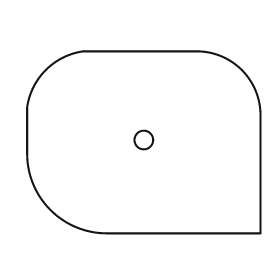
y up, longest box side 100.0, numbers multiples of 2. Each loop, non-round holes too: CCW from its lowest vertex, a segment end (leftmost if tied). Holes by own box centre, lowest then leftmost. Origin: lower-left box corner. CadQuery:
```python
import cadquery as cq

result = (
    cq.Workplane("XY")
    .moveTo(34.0, 0.0)
    .lineTo(100.0, 0.0)
    .lineTo(100.0, 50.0)
    .threePointArc((92.0, 70.0), (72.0, 78.0))
    .lineTo(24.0, 78.0)
    .threePointArc((8.0, 70.0), (0.0, 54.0))
    .lineTo(0.0, 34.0)
    .threePointArc((10.0, 10.0), (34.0, 0.0))
    .close()
    .moveTo(50.0, 40.0)
    .circle(4.0)
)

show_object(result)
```